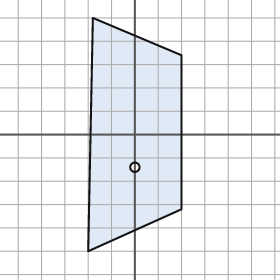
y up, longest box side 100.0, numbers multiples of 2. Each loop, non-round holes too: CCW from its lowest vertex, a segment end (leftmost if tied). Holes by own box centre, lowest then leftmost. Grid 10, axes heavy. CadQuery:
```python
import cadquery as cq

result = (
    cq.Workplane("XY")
    .moveTo(-20.0, -50.0)
    .lineTo(20.0, -32.0)
    .lineTo(20.0, 34.0)
    .lineTo(-18.0, 50.0)
    .close()
    .moveTo(0.0, -14.0)
    .circle(2.0)
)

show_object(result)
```